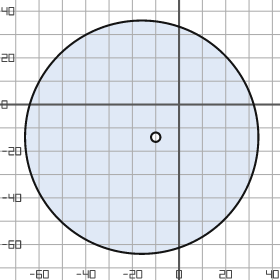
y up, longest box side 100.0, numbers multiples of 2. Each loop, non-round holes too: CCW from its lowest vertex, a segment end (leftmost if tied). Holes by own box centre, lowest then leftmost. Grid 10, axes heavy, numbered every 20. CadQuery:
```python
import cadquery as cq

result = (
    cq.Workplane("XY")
    .moveTo(-16.0, -14.0)
    .circle(50.0)
    .moveTo(-10.0, -14.0)
    .circle(2.0)
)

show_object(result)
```